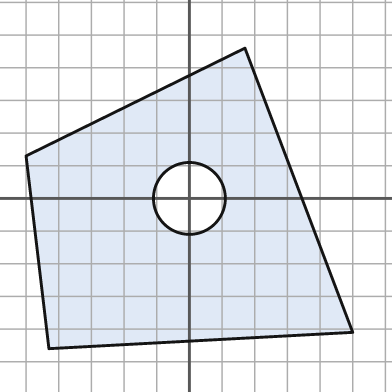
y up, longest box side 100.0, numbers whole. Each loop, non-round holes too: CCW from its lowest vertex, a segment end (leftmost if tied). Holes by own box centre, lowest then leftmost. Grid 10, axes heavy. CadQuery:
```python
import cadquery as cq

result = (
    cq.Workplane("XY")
    .moveTo(-43.0, -46.0)
    .lineTo(50.0, -41.0)
    .lineTo(17.0, 46.0)
    .lineTo(-50.0, 13.0)
    .close()
    .moveTo(0.0, 0.0)
    .circle(11.0)
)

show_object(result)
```